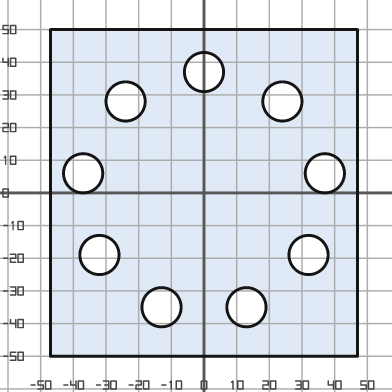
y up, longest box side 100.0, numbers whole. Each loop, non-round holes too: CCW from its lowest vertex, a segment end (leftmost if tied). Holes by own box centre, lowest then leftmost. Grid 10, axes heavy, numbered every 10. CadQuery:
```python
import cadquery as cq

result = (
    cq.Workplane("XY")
    .moveTo(-47.0, -50.0)
    .lineTo(47.0, -50.0)
    .lineTo(47.0, 50.0)
    .lineTo(-47.0, 50.0)
    .close()
    .moveTo(-13.0, -35.0)
    .circle(6.0)
    .moveTo(13.0, -35.0)
    .circle(6.0)
    .moveTo(-32.0, -19.0)
    .circle(6.0)
    .moveTo(32.0, -19.0)
    .circle(6.0)
    .moveTo(-37.0, 6.0)
    .circle(6.0)
    .moveTo(37.0, 6.0)
    .circle(6.0)
    .moveTo(-24.0, 28.0)
    .circle(6.0)
    .moveTo(24.0, 28.0)
    .circle(6.0)
    .moveTo(0.0, 37.0)
    .circle(6.0)
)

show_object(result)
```